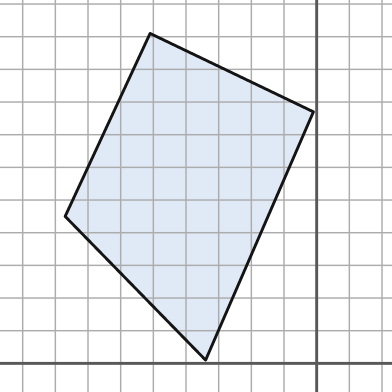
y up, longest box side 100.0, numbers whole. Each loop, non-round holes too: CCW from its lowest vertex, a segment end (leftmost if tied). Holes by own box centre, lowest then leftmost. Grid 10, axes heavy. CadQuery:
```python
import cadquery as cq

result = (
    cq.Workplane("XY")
    .moveTo(-34.0, 1.0)
    .lineTo(-1.0, 77.0)
    .lineTo(-51.0, 101.0)
    .lineTo(-77.0, 45.0)
    .close()
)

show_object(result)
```